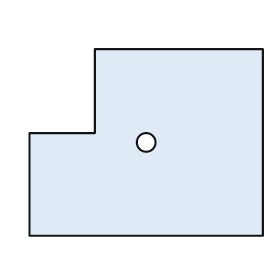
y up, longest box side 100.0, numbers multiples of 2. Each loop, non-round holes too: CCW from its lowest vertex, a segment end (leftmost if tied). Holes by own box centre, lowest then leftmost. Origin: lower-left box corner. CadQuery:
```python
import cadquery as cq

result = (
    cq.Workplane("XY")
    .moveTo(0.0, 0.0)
    .lineTo(100.0, 0.0)
    .lineTo(100.0, 80.0)
    .lineTo(28.0, 80.0)
    .lineTo(28.0, 44.0)
    .lineTo(0.0, 44.0)
    .close()
    .moveTo(50.0, 40.0)
    .circle(4.0)
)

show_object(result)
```